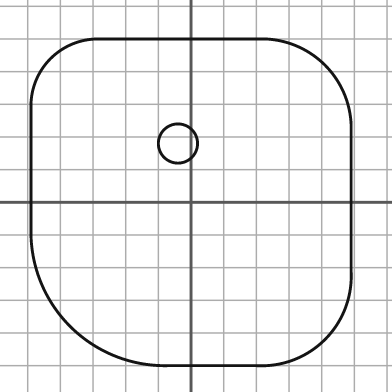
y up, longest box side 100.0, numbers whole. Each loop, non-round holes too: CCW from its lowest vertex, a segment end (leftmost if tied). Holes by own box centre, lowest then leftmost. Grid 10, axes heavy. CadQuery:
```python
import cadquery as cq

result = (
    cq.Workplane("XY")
    .moveTo(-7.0, -50.0)
    .lineTo(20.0, -50.0)
    .threePointArc((41.0, -42.0), (49.0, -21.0))
    .lineTo(49.0, 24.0)
    .threePointArc((41.0, 42.0), (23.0, 50.0))
    .lineTo(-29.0, 50.0)
    .threePointArc((-43.0, 44.0), (-49.0, 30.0))
    .lineTo(-49.0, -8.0)
    .threePointArc((-37.0, -38.0), (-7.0, -50.0))
    .close()
    .moveTo(-4.0, 18.0)
    .circle(6.0)
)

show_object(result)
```